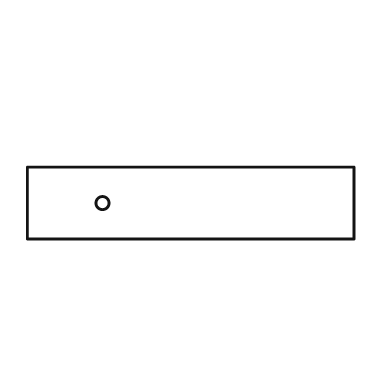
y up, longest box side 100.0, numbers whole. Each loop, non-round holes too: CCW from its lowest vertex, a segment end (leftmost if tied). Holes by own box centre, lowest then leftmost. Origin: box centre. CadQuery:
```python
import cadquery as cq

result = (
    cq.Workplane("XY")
    .moveTo(-50.0, -11.0)
    .lineTo(50.0, -11.0)
    .lineTo(50.0, 11.0)
    .lineTo(-50.0, 11.0)
    .close()
    .moveTo(-27.0, 0.0)
    .circle(2.0)
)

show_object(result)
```